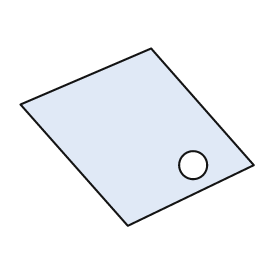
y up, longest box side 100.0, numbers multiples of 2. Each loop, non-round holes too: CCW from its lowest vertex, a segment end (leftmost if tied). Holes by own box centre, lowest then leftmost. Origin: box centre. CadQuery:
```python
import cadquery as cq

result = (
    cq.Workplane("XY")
    .moveTo(-4.0, -38.0)
    .lineTo(50.0, -12.0)
    .lineTo(6.0, 38.0)
    .lineTo(-50.0, 14.0)
    .close()
    .moveTo(24.0, -12.0)
    .circle(6.0)
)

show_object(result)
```